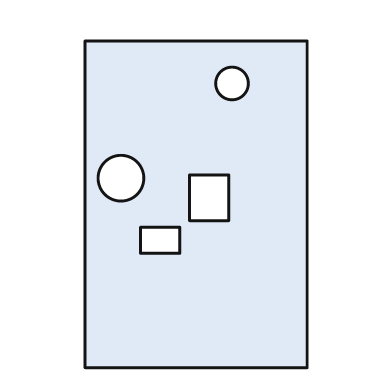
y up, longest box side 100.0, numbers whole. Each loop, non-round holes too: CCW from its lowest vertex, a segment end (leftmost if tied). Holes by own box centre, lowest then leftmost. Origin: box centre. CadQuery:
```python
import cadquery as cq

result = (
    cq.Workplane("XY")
    .moveTo(-34.0, -50.0)
    .lineTo(34.0, -50.0)
    .lineTo(34.0, 50.0)
    .lineTo(-34.0, 50.0)
    .close()
    .moveTo(-17.0, -15.0)
    .lineTo(-5.0, -15.0)
    .lineTo(-5.0, -7.0)
    .lineTo(-17.0, -7.0)
    .close()
    .moveTo(-2.0, -5.0)
    .lineTo(10.0, -5.0)
    .lineTo(10.0, 9.0)
    .lineTo(-2.0, 9.0)
    .close()
    .moveTo(-23.0, 8.0)
    .circle(7.0)
    .moveTo(11.0, 37.0)
    .circle(5.0)
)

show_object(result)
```